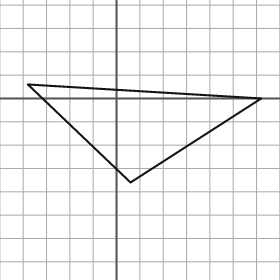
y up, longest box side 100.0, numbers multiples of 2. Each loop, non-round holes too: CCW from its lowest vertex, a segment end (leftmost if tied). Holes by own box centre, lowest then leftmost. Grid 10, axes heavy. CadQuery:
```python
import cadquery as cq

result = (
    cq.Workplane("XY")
    .moveTo(6.0, -36.0)
    .lineTo(62.0, 0.0)
    .lineTo(-38.0, 6.0)
    .close()
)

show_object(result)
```